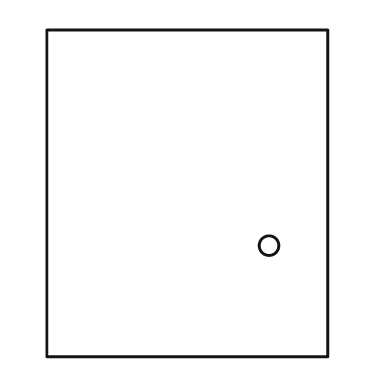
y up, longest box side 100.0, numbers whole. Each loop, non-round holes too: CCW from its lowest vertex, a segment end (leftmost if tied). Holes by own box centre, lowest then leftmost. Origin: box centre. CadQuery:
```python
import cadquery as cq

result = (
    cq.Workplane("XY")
    .moveTo(-43.0, -50.0)
    .lineTo(43.0, -50.0)
    .lineTo(43.0, 50.0)
    .lineTo(-43.0, 50.0)
    .close()
    .moveTo(25.0, -16.0)
    .circle(3.0)
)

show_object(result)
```